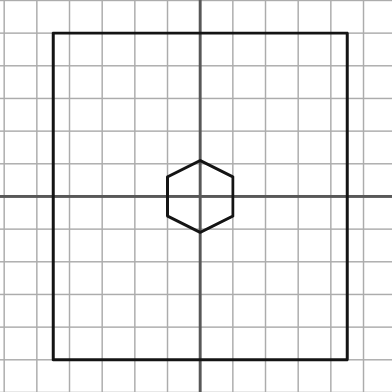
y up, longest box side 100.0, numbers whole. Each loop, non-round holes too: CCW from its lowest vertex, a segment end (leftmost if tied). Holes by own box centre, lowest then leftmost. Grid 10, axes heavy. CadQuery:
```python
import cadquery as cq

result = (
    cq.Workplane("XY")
    .moveTo(-45.0, -50.0)
    .lineTo(45.0, -50.0)
    .lineTo(45.0, 50.0)
    .lineTo(-45.0, 50.0)
    .close()
    .moveTo(0.0, -11.0)
    .lineTo(10.0, -6.0)
    .lineTo(10.0, 6.0)
    .lineTo(0.0, 11.0)
    .lineTo(-10.0, 6.0)
    .lineTo(-10.0, -6.0)
    .close()
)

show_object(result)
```